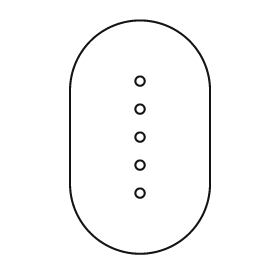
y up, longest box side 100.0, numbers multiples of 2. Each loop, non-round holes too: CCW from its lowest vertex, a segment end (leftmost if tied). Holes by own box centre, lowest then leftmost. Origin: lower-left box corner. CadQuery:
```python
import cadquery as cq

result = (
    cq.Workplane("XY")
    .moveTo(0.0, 30.0)
    .threePointArc((30.0, 0.0), (60.0, 30.0))
    .lineTo(60.0, 70.0)
    .threePointArc((30.0, 100.0), (0.0, 70.0))
    .close()
    .moveTo(30.0, 26.0)
    .circle(2.0)
    .moveTo(30.0, 38.0)
    .circle(2.0)
    .moveTo(30.0, 50.0)
    .circle(2.0)
    .moveTo(30.0, 62.0)
    .circle(2.0)
    .moveTo(30.0, 74.0)
    .circle(2.0)
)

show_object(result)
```